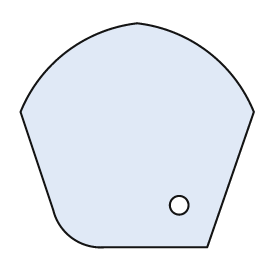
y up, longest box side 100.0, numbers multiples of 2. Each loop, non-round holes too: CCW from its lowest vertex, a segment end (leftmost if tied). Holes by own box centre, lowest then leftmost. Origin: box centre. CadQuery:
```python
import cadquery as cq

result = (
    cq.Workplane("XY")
    .moveTo(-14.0, -48.0)
    .lineTo(30.0, -48.0)
    .lineTo(50.0, 10.0)
    .threePointArc((30.0, 36.0), (0.0, 48.0))
    .threePointArc((-30.0, 36.0), (-50.0, 10.0))
    .lineTo(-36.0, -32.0)
    .threePointArc((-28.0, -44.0), (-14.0, -48.0))
    .close()
    .moveTo(18.0, -30.0)
    .circle(4.0)
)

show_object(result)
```